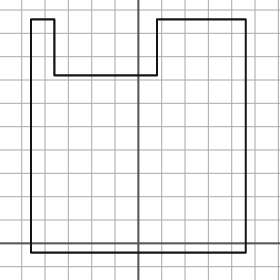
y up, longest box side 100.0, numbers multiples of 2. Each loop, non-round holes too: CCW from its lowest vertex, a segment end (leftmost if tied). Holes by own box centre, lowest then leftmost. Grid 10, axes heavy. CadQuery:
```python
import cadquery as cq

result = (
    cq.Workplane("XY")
    .moveTo(-46.0, -4.0)
    .lineTo(46.0, -4.0)
    .lineTo(46.0, 96.0)
    .lineTo(8.0, 96.0)
    .lineTo(8.0, 72.0)
    .lineTo(-36.0, 72.0)
    .lineTo(-36.0, 96.0)
    .lineTo(-46.0, 96.0)
    .close()
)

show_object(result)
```